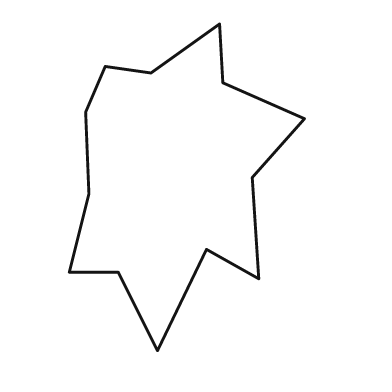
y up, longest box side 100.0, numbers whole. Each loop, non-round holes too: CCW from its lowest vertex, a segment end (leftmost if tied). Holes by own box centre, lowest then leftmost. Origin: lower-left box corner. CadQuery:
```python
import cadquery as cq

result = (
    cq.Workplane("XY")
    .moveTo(27.0, 0.0)
    .lineTo(42.0, 31.0)
    .lineTo(58.0, 22.0)
    .lineTo(56.0, 53.0)
    .lineTo(72.0, 71.0)
    .lineTo(47.0, 82.0)
    .lineTo(46.0, 100.0)
    .lineTo(25.0, 85.0)
    .lineTo(11.0, 87.0)
    .lineTo(5.0, 73.0)
    .lineTo(6.0, 48.0)
    .lineTo(0.0, 24.0)
    .lineTo(15.0, 24.0)
    .close()
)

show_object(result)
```